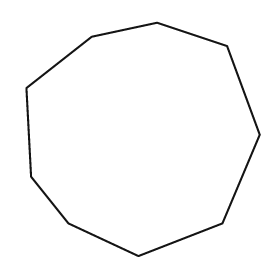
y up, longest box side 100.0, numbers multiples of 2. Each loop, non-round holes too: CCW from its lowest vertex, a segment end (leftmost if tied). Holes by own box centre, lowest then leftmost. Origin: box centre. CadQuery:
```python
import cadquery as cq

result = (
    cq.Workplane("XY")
    .moveTo(-2.0, -50.0)
    .lineTo(34.0, -36.0)
    .lineTo(50.0, 2.0)
    .lineTo(36.0, 40.0)
    .lineTo(6.0, 50.0)
    .lineTo(-22.0, 44.0)
    .lineTo(-50.0, 22.0)
    .lineTo(-48.0, -16.0)
    .lineTo(-32.0, -36.0)
    .close()
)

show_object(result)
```